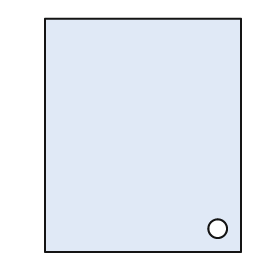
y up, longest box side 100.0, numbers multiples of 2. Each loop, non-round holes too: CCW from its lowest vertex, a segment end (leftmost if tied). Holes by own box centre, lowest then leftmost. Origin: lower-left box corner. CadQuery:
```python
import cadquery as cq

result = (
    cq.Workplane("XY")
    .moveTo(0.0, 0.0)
    .lineTo(84.0, 0.0)
    .lineTo(84.0, 100.0)
    .lineTo(0.0, 100.0)
    .close()
    .moveTo(74.0, 10.0)
    .circle(4.0)
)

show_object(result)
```